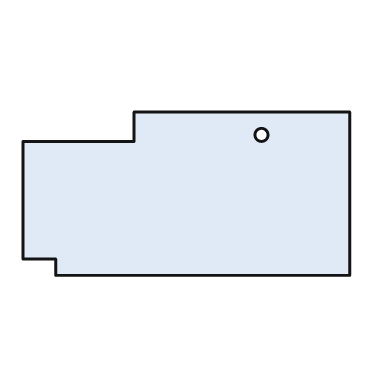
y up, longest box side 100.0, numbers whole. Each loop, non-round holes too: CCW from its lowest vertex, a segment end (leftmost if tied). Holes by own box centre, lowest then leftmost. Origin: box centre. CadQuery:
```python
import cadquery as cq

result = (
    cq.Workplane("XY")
    .moveTo(-40.0, -25.0)
    .lineTo(50.0, -25.0)
    .lineTo(50.0, 25.0)
    .lineTo(-16.0, 25.0)
    .lineTo(-16.0, 16.0)
    .lineTo(-50.0, 16.0)
    .lineTo(-50.0, -20.0)
    .lineTo(-40.0, -20.0)
    .close()
    .moveTo(23.0, 18.0)
    .circle(2.0)
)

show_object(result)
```